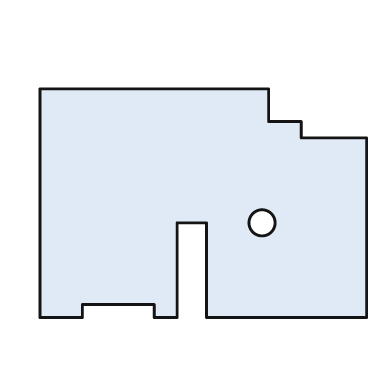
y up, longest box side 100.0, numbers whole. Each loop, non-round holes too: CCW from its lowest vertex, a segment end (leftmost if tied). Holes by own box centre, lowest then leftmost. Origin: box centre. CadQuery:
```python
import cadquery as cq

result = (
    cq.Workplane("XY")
    .moveTo(-50.0, -35.0)
    .lineTo(-37.0, -35.0)
    .lineTo(-37.0, -31.0)
    .lineTo(-15.0, -31.0)
    .lineTo(-15.0, -35.0)
    .lineTo(-8.0, -35.0)
    .lineTo(-8.0, -6.0)
    .lineTo(1.0, -6.0)
    .lineTo(1.0, -35.0)
    .lineTo(50.0, -35.0)
    .lineTo(50.0, 20.0)
    .lineTo(30.0, 20.0)
    .lineTo(30.0, 25.0)
    .lineTo(20.0, 25.0)
    .lineTo(20.0, 35.0)
    .lineTo(-50.0, 35.0)
    .close()
    .moveTo(18.0, -6.0)
    .circle(4.0)
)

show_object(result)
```